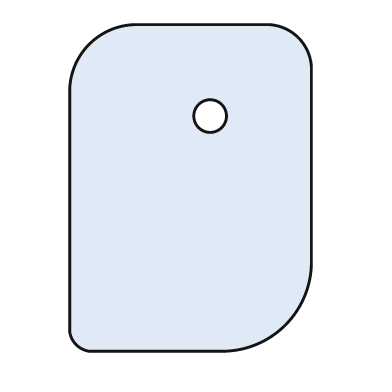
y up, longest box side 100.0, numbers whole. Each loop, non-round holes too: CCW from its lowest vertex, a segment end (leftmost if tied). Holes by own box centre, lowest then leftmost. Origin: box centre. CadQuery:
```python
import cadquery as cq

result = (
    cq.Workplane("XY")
    .moveTo(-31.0, -50.0)
    .lineTo(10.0, -50.0)
    .threePointArc((29.0, -42.0), (37.0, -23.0))
    .lineTo(37.0, 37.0)
    .threePointArc((33.0, 46.0), (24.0, 50.0))
    .lineTo(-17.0, 50.0)
    .threePointArc((-31.0, 44.0), (-37.0, 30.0))
    .lineTo(-37.0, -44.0)
    .threePointArc((-35.0, -48.0), (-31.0, -50.0))
    .close()
    .moveTo(6.0, 22.0)
    .circle(5.0)
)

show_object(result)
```